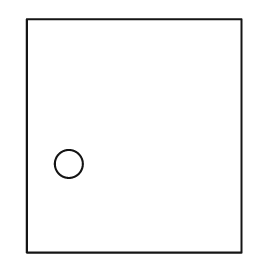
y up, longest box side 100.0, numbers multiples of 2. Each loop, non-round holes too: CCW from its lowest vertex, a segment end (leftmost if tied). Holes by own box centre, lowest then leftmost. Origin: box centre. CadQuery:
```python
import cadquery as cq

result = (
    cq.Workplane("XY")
    .moveTo(-46.0, -50.0)
    .lineTo(46.0, -50.0)
    .lineTo(46.0, 50.0)
    .lineTo(-46.0, 50.0)
    .close()
    .moveTo(-28.0, -12.0)
    .circle(6.0)
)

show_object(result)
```